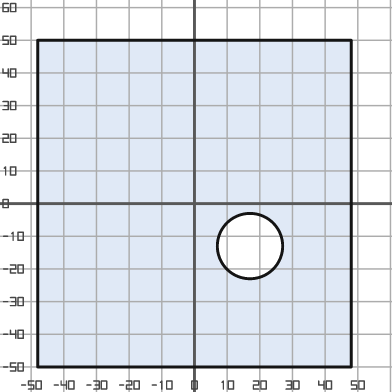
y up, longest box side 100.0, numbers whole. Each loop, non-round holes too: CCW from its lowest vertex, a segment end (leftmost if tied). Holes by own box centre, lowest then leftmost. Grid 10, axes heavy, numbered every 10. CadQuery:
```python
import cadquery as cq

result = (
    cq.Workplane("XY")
    .moveTo(-48.0, -50.0)
    .lineTo(48.0, -50.0)
    .lineTo(48.0, 50.0)
    .lineTo(-48.0, 50.0)
    .close()
    .moveTo(17.0, -13.0)
    .circle(10.0)
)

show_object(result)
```